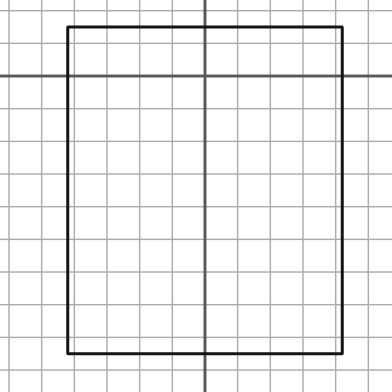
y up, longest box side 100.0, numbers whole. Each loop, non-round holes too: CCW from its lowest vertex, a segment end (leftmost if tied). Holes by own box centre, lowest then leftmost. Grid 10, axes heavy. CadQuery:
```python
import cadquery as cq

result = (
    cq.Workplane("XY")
    .moveTo(-42.0, -85.0)
    .lineTo(42.0, -85.0)
    .lineTo(42.0, 15.0)
    .lineTo(-42.0, 15.0)
    .close()
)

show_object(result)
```